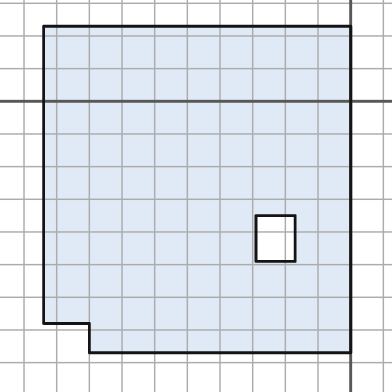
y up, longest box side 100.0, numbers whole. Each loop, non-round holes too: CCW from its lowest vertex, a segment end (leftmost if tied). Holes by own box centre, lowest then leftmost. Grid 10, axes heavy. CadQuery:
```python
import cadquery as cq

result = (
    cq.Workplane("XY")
    .moveTo(-80.0, -77.0)
    .lineTo(0.0, -77.0)
    .lineTo(0.0, 23.0)
    .lineTo(-94.0, 23.0)
    .lineTo(-94.0, -68.0)
    .lineTo(-80.0, -68.0)
    .close()
    .moveTo(-29.0, -49.0)
    .lineTo(-17.0, -49.0)
    .lineTo(-17.0, -35.0)
    .lineTo(-29.0, -35.0)
    .close()
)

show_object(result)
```